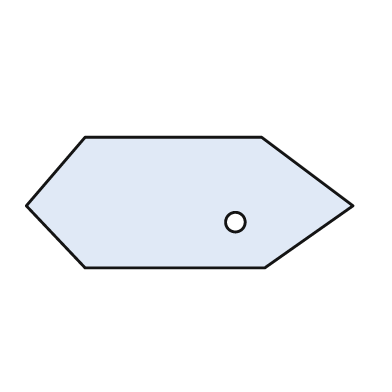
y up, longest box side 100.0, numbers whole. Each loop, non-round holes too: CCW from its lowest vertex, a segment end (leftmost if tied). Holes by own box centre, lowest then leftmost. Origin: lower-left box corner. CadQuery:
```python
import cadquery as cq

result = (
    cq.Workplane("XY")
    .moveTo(18.0, 0.0)
    .lineTo(73.0, 0.0)
    .lineTo(100.0, 19.0)
    .lineTo(72.0, 40.0)
    .lineTo(18.0, 40.0)
    .lineTo(0.0, 19.0)
    .close()
    .moveTo(64.0, 14.0)
    .circle(3.0)
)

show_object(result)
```